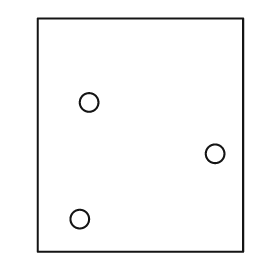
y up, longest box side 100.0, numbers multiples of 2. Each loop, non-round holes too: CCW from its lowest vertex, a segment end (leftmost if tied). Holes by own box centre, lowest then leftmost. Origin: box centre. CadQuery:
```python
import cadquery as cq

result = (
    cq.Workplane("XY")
    .moveTo(-44.0, -50.0)
    .lineTo(44.0, -50.0)
    .lineTo(44.0, 50.0)
    .lineTo(-44.0, 50.0)
    .close()
    .moveTo(-26.0, -36.0)
    .circle(4.0)
    .moveTo(32.0, -8.0)
    .circle(4.0)
    .moveTo(-22.0, 14.0)
    .circle(4.0)
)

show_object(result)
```